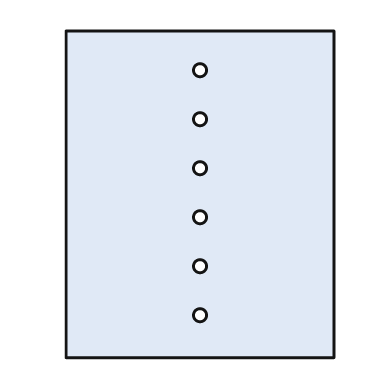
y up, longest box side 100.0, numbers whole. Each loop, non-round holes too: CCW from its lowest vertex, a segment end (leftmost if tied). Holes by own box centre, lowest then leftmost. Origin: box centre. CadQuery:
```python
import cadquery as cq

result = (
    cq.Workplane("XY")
    .moveTo(-41.0, -50.0)
    .lineTo(41.0, -50.0)
    .lineTo(41.0, 50.0)
    .lineTo(-41.0, 50.0)
    .close()
    .moveTo(0.0, -37.0)
    .circle(2.0)
    .moveTo(0.0, -22.0)
    .circle(2.0)
    .moveTo(0.0, -7.0)
    .circle(2.0)
    .moveTo(0.0, 8.0)
    .circle(2.0)
    .moveTo(0.0, 23.0)
    .circle(2.0)
    .moveTo(0.0, 38.0)
    .circle(2.0)
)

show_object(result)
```